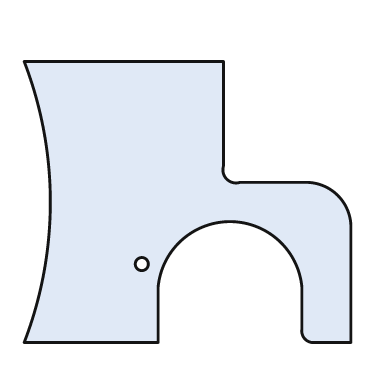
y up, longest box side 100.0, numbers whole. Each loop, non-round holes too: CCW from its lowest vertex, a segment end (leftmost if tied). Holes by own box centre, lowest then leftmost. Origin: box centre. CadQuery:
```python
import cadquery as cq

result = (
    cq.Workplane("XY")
    .moveTo(-50.0, -43.0)
    .lineTo(-9.0, -43.0)
    .lineTo(-9.0, -26.0)
    .threePointArc((13.0, -6.0), (35.0, -26.0))
    .lineTo(35.0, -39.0)
    .threePointArc((36.0, -42.0), (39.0, -43.0))
    .lineTo(50.0, -43.0)
    .lineTo(50.0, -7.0)
    .threePointArc((46.0, 2.0), (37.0, 6.0))
    .lineTo(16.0, 6.0)
    .threePointArc((12.0, 7.0), (11.0, 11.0))
    .lineTo(11.0, 43.0)
    .lineTo(-50.0, 43.0)
    .threePointArc((-42.0, 0.0), (-50.0, -43.0))
    .close()
    .moveTo(-14.0, -19.0)
    .circle(2.0)
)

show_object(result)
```